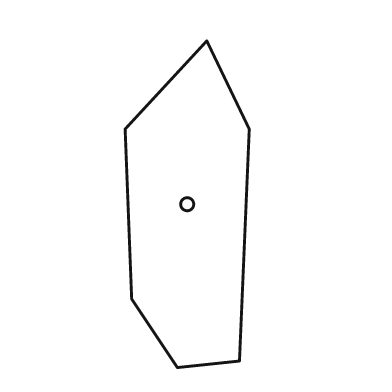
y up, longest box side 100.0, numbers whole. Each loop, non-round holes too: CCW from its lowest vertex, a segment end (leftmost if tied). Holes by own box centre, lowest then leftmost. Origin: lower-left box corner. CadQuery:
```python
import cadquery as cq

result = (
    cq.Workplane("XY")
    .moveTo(16.0, 0.0)
    .lineTo(35.0, 2.0)
    .lineTo(38.0, 73.0)
    .lineTo(25.0, 100.0)
    .lineTo(0.0, 73.0)
    .lineTo(2.0, 21.0)
    .close()
    .moveTo(19.0, 50.0)
    .circle(2.0)
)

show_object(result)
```